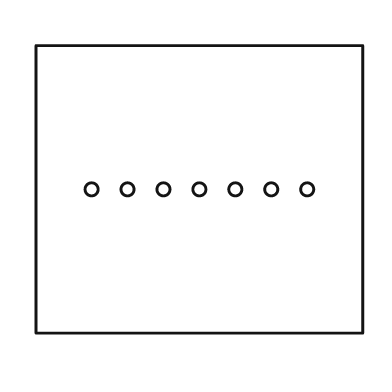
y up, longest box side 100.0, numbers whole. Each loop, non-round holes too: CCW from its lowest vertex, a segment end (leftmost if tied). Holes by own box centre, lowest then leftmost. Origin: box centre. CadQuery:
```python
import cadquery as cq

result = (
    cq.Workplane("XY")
    .moveTo(-50.0, -44.0)
    .lineTo(50.0, -44.0)
    .lineTo(50.0, 44.0)
    .lineTo(-50.0, 44.0)
    .close()
    .moveTo(-33.0, 0.0)
    .circle(2.0)
    .moveTo(-22.0, 0.0)
    .circle(2.0)
    .moveTo(-11.0, 0.0)
    .circle(2.0)
    .moveTo(0.0, 0.0)
    .circle(2.0)
    .moveTo(11.0, 0.0)
    .circle(2.0)
    .moveTo(22.0, 0.0)
    .circle(2.0)
    .moveTo(33.0, 0.0)
    .circle(2.0)
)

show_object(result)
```